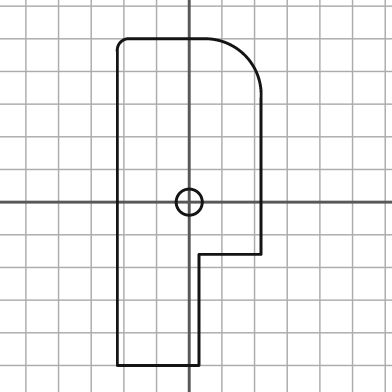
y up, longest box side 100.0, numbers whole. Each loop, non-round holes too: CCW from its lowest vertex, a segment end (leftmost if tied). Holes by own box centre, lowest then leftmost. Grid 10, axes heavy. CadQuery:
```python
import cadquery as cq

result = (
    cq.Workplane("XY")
    .moveTo(-22.0, -50.0)
    .lineTo(3.0, -50.0)
    .lineTo(3.0, -16.0)
    .lineTo(22.0, -16.0)
    .lineTo(22.0, 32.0)
    .threePointArc((17.0, 45.0), (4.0, 50.0))
    .lineTo(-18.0, 50.0)
    .threePointArc((-21.0, 49.0), (-22.0, 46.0))
    .close()
    .moveTo(0.0, 0.0)
    .circle(4.0)
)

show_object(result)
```